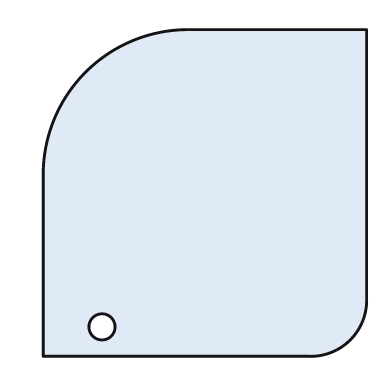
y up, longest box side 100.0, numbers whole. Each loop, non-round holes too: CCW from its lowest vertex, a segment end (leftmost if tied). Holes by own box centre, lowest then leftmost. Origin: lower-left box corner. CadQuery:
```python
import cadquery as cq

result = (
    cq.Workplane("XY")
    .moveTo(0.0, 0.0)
    .lineTo(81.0, 0.0)
    .threePointArc((94.0, 5.0), (99.0, 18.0))
    .lineTo(99.0, 100.0)
    .lineTo(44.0, 100.0)
    .threePointArc((13.0, 87.0), (0.0, 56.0))
    .close()
    .moveTo(18.0, 9.0)
    .circle(4.0)
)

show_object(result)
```